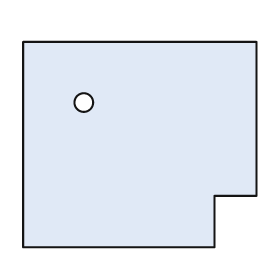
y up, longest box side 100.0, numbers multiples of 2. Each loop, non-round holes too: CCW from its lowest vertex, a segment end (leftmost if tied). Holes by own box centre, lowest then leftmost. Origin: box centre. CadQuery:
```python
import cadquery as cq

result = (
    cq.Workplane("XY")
    .moveTo(-50.0, -44.0)
    .lineTo(32.0, -44.0)
    .lineTo(32.0, -22.0)
    .lineTo(50.0, -22.0)
    .lineTo(50.0, 44.0)
    .lineTo(-50.0, 44.0)
    .close()
    .moveTo(-24.0, 18.0)
    .circle(4.0)
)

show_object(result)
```